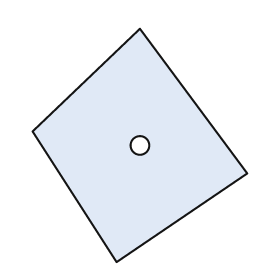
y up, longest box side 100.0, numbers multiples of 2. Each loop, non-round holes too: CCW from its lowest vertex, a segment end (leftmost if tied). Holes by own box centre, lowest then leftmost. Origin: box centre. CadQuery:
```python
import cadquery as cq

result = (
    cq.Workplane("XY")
    .moveTo(-10.0, -50.0)
    .lineTo(46.0, -12.0)
    .lineTo(0.0, 50.0)
    .lineTo(-46.0, 6.0)
    .close()
    .moveTo(0.0, 0.0)
    .circle(4.0)
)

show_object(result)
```